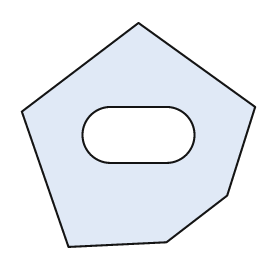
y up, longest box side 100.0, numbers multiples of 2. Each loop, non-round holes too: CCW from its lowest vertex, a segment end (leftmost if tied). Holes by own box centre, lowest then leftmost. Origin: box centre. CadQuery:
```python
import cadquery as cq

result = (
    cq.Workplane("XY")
    .moveTo(-30.0, -48.0)
    .lineTo(12.0, -46.0)
    .lineTo(38.0, -26.0)
    .lineTo(50.0, 12.0)
    .lineTo(0.0, 48.0)
    .lineTo(-50.0, 10.0)
    .close()
    .moveTo(-12.0, -12.0)
    .lineTo(12.0, -12.0)
    .threePointArc((24.0, 0.0), (12.0, 12.0))
    .lineTo(-12.0, 12.0)
    .threePointArc((-24.0, 0.0), (-12.0, -12.0))
    .close()
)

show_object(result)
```